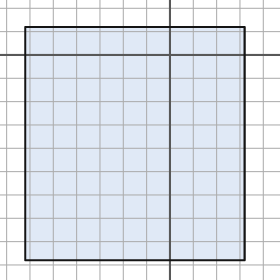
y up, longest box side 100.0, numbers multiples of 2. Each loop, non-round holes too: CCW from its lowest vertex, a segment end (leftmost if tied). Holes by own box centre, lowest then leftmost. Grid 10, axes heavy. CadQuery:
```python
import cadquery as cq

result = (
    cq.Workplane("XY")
    .moveTo(-62.0, -88.0)
    .lineTo(32.0, -88.0)
    .lineTo(32.0, 12.0)
    .lineTo(-62.0, 12.0)
    .close()
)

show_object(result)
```